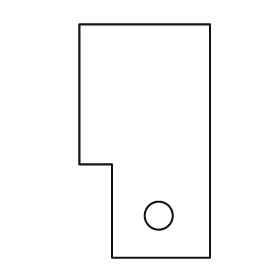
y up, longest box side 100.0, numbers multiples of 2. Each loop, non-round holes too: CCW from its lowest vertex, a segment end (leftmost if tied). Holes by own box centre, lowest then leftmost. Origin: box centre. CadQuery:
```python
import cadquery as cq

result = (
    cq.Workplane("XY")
    .moveTo(-14.0, -50.0)
    .lineTo(28.0, -50.0)
    .lineTo(28.0, 50.0)
    .lineTo(-28.0, 50.0)
    .lineTo(-28.0, -10.0)
    .lineTo(-14.0, -10.0)
    .close()
    .moveTo(6.0, -32.0)
    .circle(6.0)
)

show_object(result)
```